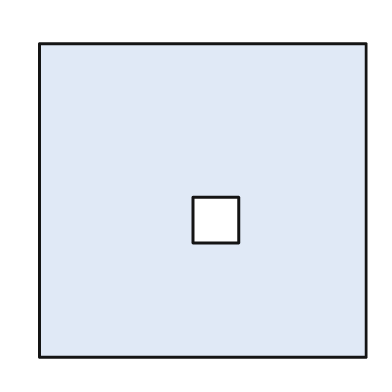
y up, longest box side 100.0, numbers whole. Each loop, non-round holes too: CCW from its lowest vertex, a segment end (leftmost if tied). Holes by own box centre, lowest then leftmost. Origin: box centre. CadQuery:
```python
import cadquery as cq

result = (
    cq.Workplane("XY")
    .moveTo(-50.0, -48.0)
    .lineTo(50.0, -48.0)
    .lineTo(50.0, 48.0)
    .lineTo(-50.0, 48.0)
    .close()
    .moveTo(-3.0, -13.0)
    .lineTo(11.0, -13.0)
    .lineTo(11.0, 1.0)
    .lineTo(-3.0, 1.0)
    .close()
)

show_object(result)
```